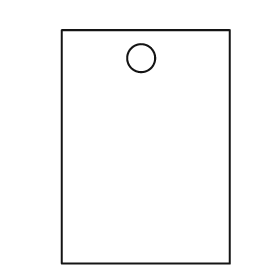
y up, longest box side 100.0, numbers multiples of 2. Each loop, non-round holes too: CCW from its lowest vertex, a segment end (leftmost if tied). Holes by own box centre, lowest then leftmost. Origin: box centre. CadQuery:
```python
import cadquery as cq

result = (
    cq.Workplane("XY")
    .moveTo(-36.0, -50.0)
    .lineTo(36.0, -50.0)
    .lineTo(36.0, 50.0)
    .lineTo(-36.0, 50.0)
    .close()
    .moveTo(-2.0, 38.0)
    .circle(6.0)
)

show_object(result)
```